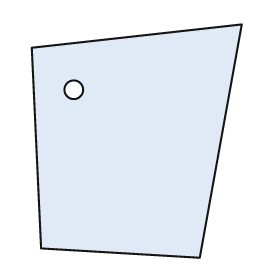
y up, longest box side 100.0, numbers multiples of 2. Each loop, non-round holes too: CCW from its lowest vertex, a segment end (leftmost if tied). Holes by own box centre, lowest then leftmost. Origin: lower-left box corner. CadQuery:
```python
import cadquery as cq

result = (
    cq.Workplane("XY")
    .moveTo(72.0, 0.0)
    .lineTo(90.0, 100.0)
    .lineTo(0.0, 90.0)
    .lineTo(4.0, 4.0)
    .close()
    .moveTo(18.0, 72.0)
    .circle(4.0)
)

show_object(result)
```